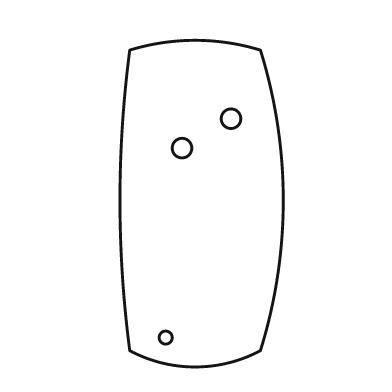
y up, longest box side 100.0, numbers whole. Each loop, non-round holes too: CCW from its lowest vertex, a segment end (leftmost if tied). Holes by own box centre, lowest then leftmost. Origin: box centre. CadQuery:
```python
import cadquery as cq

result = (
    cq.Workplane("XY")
    .moveTo(-22.0, -45.0)
    .threePointArc((-2.0, -50.0), (18.0, -45.0))
    .threePointArc((25.0, 1.0), (18.0, 47.0))
    .threePointArc((-2.0, 50.0), (-22.0, 47.0))
    .threePointArc((-25.0, 1.0), (-22.0, -45.0))
    .close()
    .moveTo(-11.0, -41.0)
    .circle(2.0)
    .moveTo(-6.0, 17.0)
    .circle(3.0)
    .moveTo(9.0, 26.0)
    .circle(3.0)
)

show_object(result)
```